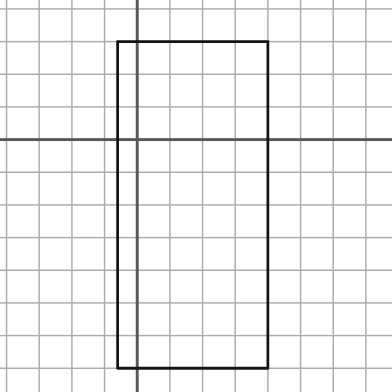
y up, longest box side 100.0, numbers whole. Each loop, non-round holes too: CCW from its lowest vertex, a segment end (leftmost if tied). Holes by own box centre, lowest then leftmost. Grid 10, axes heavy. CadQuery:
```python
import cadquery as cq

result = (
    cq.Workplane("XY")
    .moveTo(-6.0, -70.0)
    .lineTo(40.0, -70.0)
    .lineTo(40.0, 30.0)
    .lineTo(-6.0, 30.0)
    .close()
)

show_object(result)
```